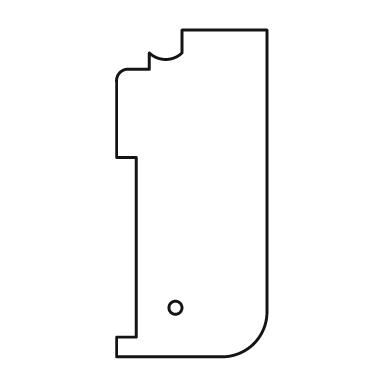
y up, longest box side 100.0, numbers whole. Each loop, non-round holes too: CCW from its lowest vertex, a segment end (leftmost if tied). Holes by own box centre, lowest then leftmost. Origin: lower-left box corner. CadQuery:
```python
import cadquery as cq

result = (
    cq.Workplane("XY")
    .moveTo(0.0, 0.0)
    .lineTo(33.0, 0.0)
    .threePointArc((42.0, 4.0), (46.0, 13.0))
    .lineTo(46.0, 100.0)
    .lineTo(20.0, 100.0)
    .lineTo(20.0, 93.0)
    .threePointArc((15.0, 91.0), (10.0, 93.0))
    .lineTo(10.0, 88.0)
    .lineTo(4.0, 88.0)
    .threePointArc((1.0, 87.0), (0.0, 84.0))
    .lineTo(0.0, 61.0)
    .lineTo(6.0, 61.0)
    .lineTo(6.0, 6.0)
    .lineTo(0.0, 6.0)
    .close()
    .moveTo(18.0, 15.0)
    .circle(2.0)
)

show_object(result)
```